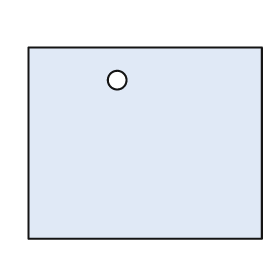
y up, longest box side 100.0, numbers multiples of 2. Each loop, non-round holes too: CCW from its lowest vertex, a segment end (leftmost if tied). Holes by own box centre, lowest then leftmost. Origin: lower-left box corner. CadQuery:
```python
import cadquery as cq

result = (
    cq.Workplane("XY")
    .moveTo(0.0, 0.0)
    .lineTo(100.0, 0.0)
    .lineTo(100.0, 82.0)
    .lineTo(0.0, 82.0)
    .close()
    .moveTo(38.0, 68.0)
    .circle(4.0)
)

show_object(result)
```